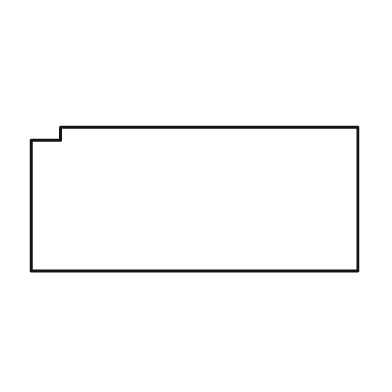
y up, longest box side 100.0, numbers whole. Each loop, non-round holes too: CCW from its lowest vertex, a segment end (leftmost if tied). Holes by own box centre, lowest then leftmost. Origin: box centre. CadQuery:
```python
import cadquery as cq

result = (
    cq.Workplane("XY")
    .moveTo(-50.0, -22.0)
    .lineTo(50.0, -22.0)
    .lineTo(50.0, 22.0)
    .lineTo(-41.0, 22.0)
    .lineTo(-41.0, 18.0)
    .lineTo(-50.0, 18.0)
    .close()
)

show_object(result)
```